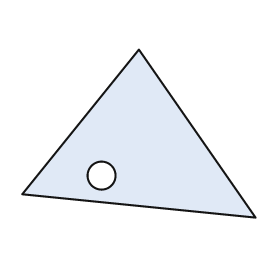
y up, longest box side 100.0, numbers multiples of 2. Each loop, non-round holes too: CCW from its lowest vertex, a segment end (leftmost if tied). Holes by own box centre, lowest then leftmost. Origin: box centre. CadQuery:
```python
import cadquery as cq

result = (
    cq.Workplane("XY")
    .moveTo(50.0, -36.0)
    .lineTo(0.0, 36.0)
    .lineTo(-50.0, -26.0)
    .close()
    .moveTo(-16.0, -18.0)
    .circle(6.0)
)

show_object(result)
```